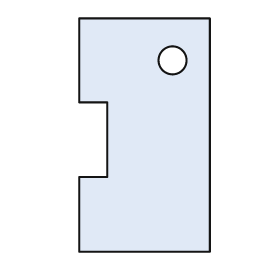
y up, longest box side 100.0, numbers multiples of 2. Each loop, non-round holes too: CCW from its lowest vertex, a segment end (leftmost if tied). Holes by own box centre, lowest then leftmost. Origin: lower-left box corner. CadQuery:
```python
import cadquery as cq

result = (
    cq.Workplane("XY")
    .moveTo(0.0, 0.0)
    .lineTo(56.0, 0.0)
    .lineTo(56.0, 100.0)
    .lineTo(0.0, 100.0)
    .lineTo(0.0, 64.0)
    .lineTo(12.0, 64.0)
    .lineTo(12.0, 32.0)
    .lineTo(0.0, 32.0)
    .close()
    .moveTo(40.0, 82.0)
    .circle(6.0)
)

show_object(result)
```